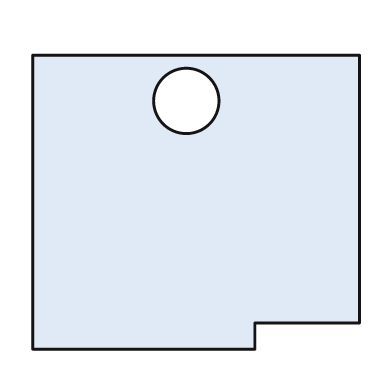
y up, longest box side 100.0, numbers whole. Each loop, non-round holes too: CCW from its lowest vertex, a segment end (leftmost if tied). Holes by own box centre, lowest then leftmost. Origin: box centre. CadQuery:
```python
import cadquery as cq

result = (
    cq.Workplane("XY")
    .moveTo(-50.0, -45.0)
    .lineTo(18.0, -45.0)
    .lineTo(18.0, -37.0)
    .lineTo(50.0, -37.0)
    .lineTo(50.0, 45.0)
    .lineTo(-50.0, 45.0)
    .close()
    .moveTo(-3.0, 31.0)
    .circle(10.0)
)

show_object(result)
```